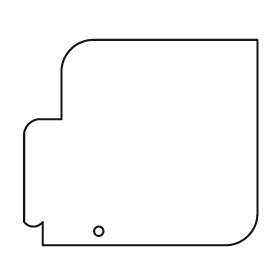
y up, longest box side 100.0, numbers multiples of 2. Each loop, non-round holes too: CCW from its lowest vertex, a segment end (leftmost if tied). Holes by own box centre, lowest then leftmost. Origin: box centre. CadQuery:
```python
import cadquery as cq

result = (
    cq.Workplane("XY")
    .moveTo(-42.0, -44.0)
    .lineTo(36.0, -44.0)
    .threePointArc((46.0, -40.0), (50.0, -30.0))
    .lineTo(50.0, 44.0)
    .lineTo(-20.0, 44.0)
    .threePointArc((-30.0, 40.0), (-34.0, 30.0))
    .lineTo(-34.0, 10.0)
    .lineTo(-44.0, 10.0)
    .threePointArc((-48.0, 8.0), (-50.0, 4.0))
    .lineTo(-50.0, -34.0)
    .threePointArc((-46.0, -36.0), (-42.0, -34.0))
    .close()
    .moveTo(-18.0, -38.0)
    .circle(2.0)
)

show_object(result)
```